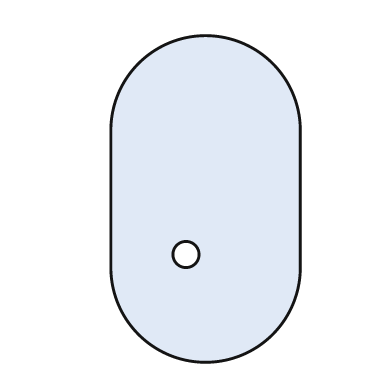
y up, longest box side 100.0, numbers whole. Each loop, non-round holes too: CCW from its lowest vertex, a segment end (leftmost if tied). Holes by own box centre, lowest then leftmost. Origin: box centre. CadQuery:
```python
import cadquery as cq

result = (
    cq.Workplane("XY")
    .moveTo(-29.0, -21.0)
    .threePointArc((0.0, -50.0), (29.0, -21.0))
    .lineTo(29.0, 21.0)
    .threePointArc((0.0, 50.0), (-29.0, 21.0))
    .close()
    .moveTo(-6.0, -17.0)
    .circle(4.0)
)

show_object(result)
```